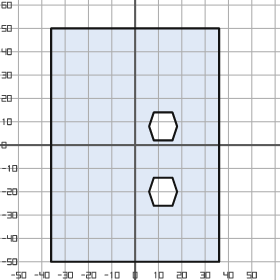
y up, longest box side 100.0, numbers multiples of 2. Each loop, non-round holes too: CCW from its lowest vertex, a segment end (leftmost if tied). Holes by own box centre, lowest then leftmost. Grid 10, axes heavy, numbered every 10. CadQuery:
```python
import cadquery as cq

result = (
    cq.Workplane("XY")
    .moveTo(-36.0, -50.0)
    .lineTo(36.0, -50.0)
    .lineTo(36.0, 50.0)
    .lineTo(-36.0, 50.0)
    .close()
    .moveTo(8.0, -26.0)
    .lineTo(16.0, -26.0)
    .lineTo(18.0, -20.0)
    .lineTo(16.0, -14.0)
    .lineTo(8.0, -14.0)
    .lineTo(6.0, -20.0)
    .close()
    .moveTo(8.0, 2.0)
    .lineTo(16.0, 2.0)
    .lineTo(18.0, 8.0)
    .lineTo(16.0, 14.0)
    .lineTo(8.0, 14.0)
    .lineTo(6.0, 8.0)
    .close()
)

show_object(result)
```